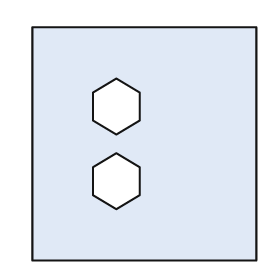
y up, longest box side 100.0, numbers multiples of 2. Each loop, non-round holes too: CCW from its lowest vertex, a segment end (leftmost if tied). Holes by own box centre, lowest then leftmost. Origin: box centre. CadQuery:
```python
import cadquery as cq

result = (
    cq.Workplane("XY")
    .moveTo(-48.0, -50.0)
    .lineTo(48.0, -50.0)
    .lineTo(48.0, 50.0)
    .lineTo(-48.0, 50.0)
    .close()
    .moveTo(-12.0, -28.0)
    .lineTo(-2.0, -22.0)
    .lineTo(-2.0, -10.0)
    .lineTo(-12.0, -4.0)
    .lineTo(-22.0, -10.0)
    .lineTo(-22.0, -22.0)
    .close()
    .moveTo(-12.0, 4.0)
    .lineTo(-2.0, 10.0)
    .lineTo(-2.0, 22.0)
    .lineTo(-12.0, 28.0)
    .lineTo(-22.0, 22.0)
    .lineTo(-22.0, 10.0)
    .close()
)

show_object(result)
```